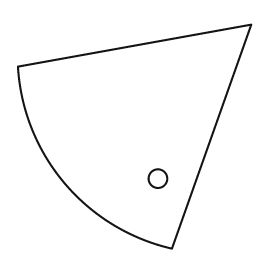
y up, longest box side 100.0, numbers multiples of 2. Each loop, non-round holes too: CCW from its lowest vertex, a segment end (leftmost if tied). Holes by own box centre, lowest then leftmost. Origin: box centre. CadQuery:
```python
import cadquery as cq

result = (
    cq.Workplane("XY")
    .moveTo(16.0, -48.0)
    .lineTo(50.0, 48.0)
    .lineTo(-50.0, 30.0)
    .threePointArc((-30.0, -20.0), (16.0, -48.0))
    .close()
    .moveTo(10.0, -18.0)
    .circle(4.0)
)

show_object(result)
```